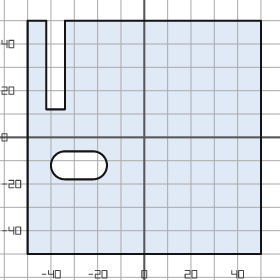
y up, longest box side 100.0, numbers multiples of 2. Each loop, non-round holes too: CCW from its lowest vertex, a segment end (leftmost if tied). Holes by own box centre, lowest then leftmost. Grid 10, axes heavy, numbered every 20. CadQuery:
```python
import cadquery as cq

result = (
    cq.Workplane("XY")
    .moveTo(-50.0, -50.0)
    .lineTo(50.0, -50.0)
    .lineTo(50.0, 50.0)
    .lineTo(-34.0, 50.0)
    .lineTo(-34.0, 12.0)
    .lineTo(-42.0, 12.0)
    .lineTo(-42.0, 50.0)
    .lineTo(-50.0, 50.0)
    .close()
    .moveTo(-34.0, -18.0)
    .lineTo(-22.0, -18.0)
    .threePointArc((-16.0, -12.0), (-22.0, -6.0))
    .lineTo(-34.0, -6.0)
    .threePointArc((-40.0, -12.0), (-34.0, -18.0))
    .close()
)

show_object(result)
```